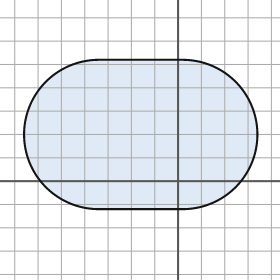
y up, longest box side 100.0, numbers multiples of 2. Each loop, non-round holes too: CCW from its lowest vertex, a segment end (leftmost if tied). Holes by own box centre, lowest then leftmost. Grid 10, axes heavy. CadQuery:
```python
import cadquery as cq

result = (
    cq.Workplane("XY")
    .moveTo(-34.0, -12.0)
    .lineTo(2.0, -12.0)
    .threePointArc((34.0, 20.0), (2.0, 52.0))
    .lineTo(-34.0, 52.0)
    .threePointArc((-66.0, 20.0), (-34.0, -12.0))
    .close()
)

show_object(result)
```